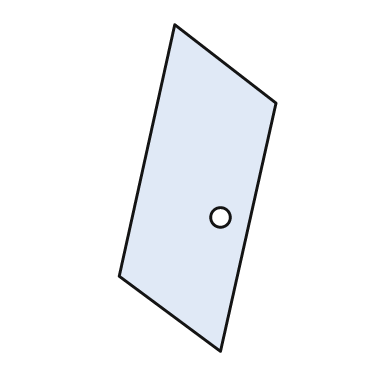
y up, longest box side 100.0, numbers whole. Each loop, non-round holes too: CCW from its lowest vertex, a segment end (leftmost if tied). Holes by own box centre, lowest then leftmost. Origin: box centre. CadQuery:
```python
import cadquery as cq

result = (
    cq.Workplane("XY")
    .moveTo(7.0, -50.0)
    .lineTo(24.0, 26.0)
    .lineTo(-7.0, 50.0)
    .lineTo(-24.0, -27.0)
    .close()
    .moveTo(7.0, -9.0)
    .circle(3.0)
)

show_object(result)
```